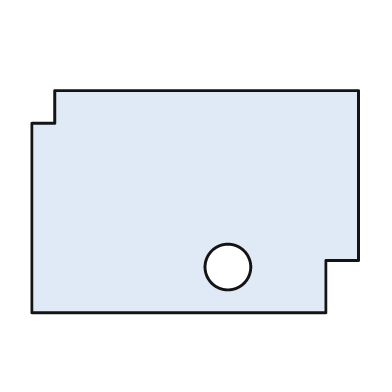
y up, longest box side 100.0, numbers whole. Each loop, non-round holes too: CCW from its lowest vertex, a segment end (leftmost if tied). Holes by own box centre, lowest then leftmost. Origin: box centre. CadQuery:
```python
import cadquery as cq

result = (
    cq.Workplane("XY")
    .moveTo(-50.0, -34.0)
    .lineTo(40.0, -34.0)
    .lineTo(40.0, -18.0)
    .lineTo(50.0, -18.0)
    .lineTo(50.0, 34.0)
    .lineTo(-43.0, 34.0)
    .lineTo(-43.0, 24.0)
    .lineTo(-50.0, 24.0)
    .close()
    .moveTo(10.0, -20.0)
    .circle(7.0)
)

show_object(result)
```